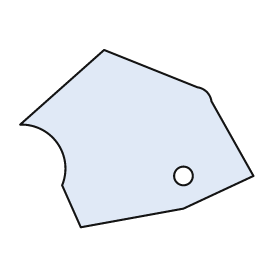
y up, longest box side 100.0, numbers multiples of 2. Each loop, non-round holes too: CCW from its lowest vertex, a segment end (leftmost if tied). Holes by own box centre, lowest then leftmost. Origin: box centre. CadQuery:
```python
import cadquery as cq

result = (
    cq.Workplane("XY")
    .moveTo(-24.0, -38.0)
    .lineTo(20.0, -30.0)
    .lineTo(50.0, -16.0)
    .lineTo(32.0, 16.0)
    .threePointArc((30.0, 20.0), (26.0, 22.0))
    .lineTo(-14.0, 38.0)
    .lineTo(-50.0, 6.0)
    .threePointArc((-34.0, -2.0), (-32.0, -20.0))
    .close()
    .moveTo(20.0, -16.0)
    .circle(4.0)
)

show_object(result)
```